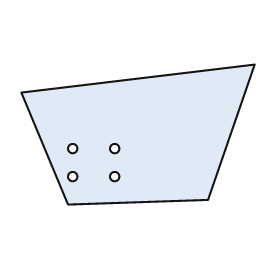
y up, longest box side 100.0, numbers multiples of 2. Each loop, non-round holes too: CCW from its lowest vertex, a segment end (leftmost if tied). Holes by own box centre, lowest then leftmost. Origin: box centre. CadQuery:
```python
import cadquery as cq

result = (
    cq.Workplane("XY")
    .moveTo(-30.0, -30.0)
    .lineTo(30.0, -28.0)
    .lineTo(50.0, 30.0)
    .lineTo(-50.0, 18.0)
    .close()
    .moveTo(-28.0, -18.0)
    .circle(2.0)
    .moveTo(-10.0, -18.0)
    .circle(2.0)
    .moveTo(-28.0, -6.0)
    .circle(2.0)
    .moveTo(-10.0, -6.0)
    .circle(2.0)
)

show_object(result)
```